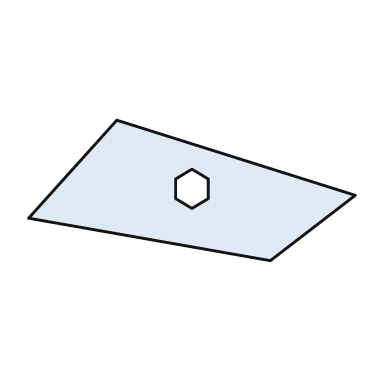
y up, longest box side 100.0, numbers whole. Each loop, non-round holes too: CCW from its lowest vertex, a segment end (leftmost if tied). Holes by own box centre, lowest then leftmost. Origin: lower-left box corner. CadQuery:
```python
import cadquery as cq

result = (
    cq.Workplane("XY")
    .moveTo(74.0, 0.0)
    .lineTo(100.0, 20.0)
    .lineTo(27.0, 43.0)
    .lineTo(0.0, 13.0)
    .close()
    .moveTo(50.0, 16.0)
    .lineTo(55.0, 19.0)
    .lineTo(55.0, 25.0)
    .lineTo(50.0, 28.0)
    .lineTo(45.0, 25.0)
    .lineTo(45.0, 19.0)
    .close()
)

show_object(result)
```